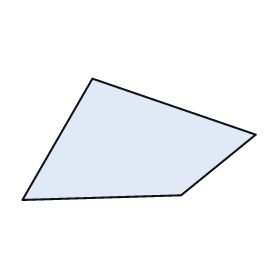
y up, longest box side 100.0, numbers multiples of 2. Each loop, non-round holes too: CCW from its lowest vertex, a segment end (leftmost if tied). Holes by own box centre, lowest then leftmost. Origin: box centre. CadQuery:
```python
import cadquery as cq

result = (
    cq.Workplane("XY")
    .moveTo(-50.0, -26.0)
    .lineTo(18.0, -24.0)
    .lineTo(50.0, 2.0)
    .lineTo(-20.0, 26.0)
    .close()
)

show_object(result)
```